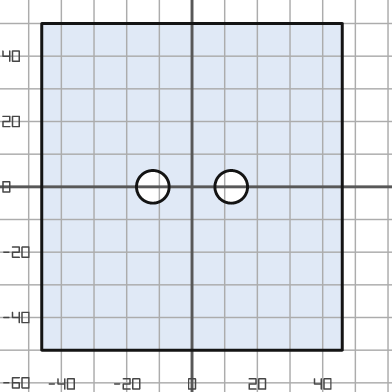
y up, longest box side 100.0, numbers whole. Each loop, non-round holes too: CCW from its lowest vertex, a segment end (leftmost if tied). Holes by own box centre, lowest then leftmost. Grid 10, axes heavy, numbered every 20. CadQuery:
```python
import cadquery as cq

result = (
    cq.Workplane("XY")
    .moveTo(-46.0, -50.0)
    .lineTo(46.0, -50.0)
    .lineTo(46.0, 50.0)
    .lineTo(-46.0, 50.0)
    .close()
    .moveTo(-12.0, 0.0)
    .circle(5.0)
    .moveTo(12.0, 0.0)
    .circle(5.0)
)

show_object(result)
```